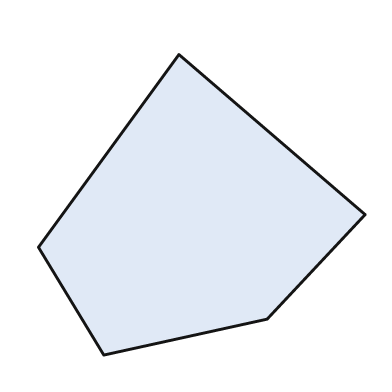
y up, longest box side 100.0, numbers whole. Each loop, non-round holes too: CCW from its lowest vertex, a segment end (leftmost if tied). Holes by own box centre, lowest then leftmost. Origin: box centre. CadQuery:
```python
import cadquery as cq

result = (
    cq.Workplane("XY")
    .moveTo(-30.0, -46.0)
    .lineTo(20.0, -35.0)
    .lineTo(50.0, -3.0)
    .lineTo(-7.0, 46.0)
    .lineTo(-50.0, -13.0)
    .close()
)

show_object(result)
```